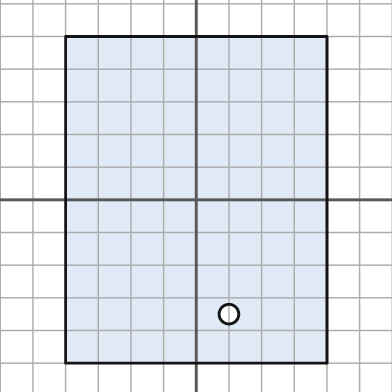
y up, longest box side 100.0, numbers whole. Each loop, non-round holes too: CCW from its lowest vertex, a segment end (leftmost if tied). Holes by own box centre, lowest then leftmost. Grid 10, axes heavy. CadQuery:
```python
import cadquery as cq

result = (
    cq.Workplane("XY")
    .moveTo(-40.0, -50.0)
    .lineTo(40.0, -50.0)
    .lineTo(40.0, 50.0)
    .lineTo(-40.0, 50.0)
    .close()
    .moveTo(10.0, -35.0)
    .circle(3.0)
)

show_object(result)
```